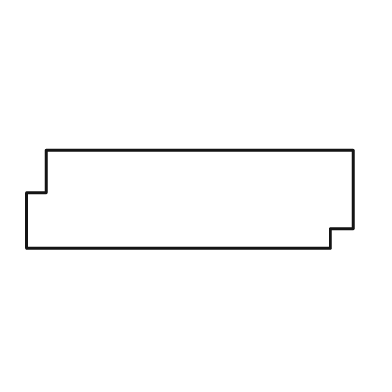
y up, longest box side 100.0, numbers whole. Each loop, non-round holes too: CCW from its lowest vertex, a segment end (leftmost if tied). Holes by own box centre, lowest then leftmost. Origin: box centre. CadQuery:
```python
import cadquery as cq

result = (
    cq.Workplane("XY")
    .moveTo(-50.0, -15.0)
    .lineTo(43.0, -15.0)
    .lineTo(43.0, -9.0)
    .lineTo(50.0, -9.0)
    .lineTo(50.0, 15.0)
    .lineTo(-44.0, 15.0)
    .lineTo(-44.0, 2.0)
    .lineTo(-50.0, 2.0)
    .close()
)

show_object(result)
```